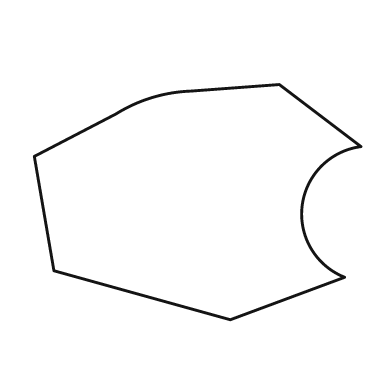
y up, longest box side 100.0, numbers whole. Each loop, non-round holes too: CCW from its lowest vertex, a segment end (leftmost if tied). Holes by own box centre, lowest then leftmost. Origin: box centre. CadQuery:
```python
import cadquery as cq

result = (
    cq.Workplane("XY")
    .moveTo(10.0, -36.0)
    .lineTo(45.0, -23.0)
    .threePointArc((32.0, -1.0), (50.0, 17.0))
    .lineTo(25.0, 36.0)
    .lineTo(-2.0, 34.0)
    .threePointArc((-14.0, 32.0), (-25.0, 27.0))
    .lineTo(-50.0, 14.0)
    .lineTo(-44.0, -21.0)
    .close()
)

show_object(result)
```